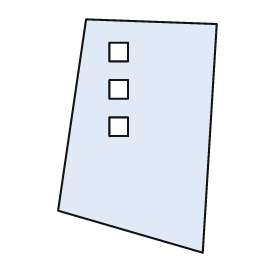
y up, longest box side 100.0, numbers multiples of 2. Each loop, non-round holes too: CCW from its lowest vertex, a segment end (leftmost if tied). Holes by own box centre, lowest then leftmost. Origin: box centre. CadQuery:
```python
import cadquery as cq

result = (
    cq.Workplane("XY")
    .moveTo(28.0, -50.0)
    .lineTo(34.0, 48.0)
    .lineTo(-22.0, 50.0)
    .lineTo(-34.0, -32.0)
    .close()
    .moveTo(-12.0, 0.0)
    .lineTo(-4.0, 0.0)
    .lineTo(-4.0, 8.0)
    .lineTo(-12.0, 8.0)
    .close()
    .moveTo(-12.0, 16.0)
    .lineTo(-4.0, 16.0)
    .lineTo(-4.0, 24.0)
    .lineTo(-12.0, 24.0)
    .close()
    .moveTo(-12.0, 32.0)
    .lineTo(-4.0, 32.0)
    .lineTo(-4.0, 40.0)
    .lineTo(-12.0, 40.0)
    .close()
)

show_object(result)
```